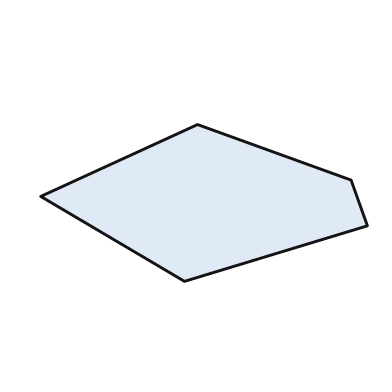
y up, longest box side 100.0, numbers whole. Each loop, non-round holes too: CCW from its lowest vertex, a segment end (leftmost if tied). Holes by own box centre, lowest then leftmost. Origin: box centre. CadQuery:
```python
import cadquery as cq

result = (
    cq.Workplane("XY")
    .moveTo(-6.0, -24.0)
    .lineTo(50.0, -7.0)
    .lineTo(45.0, 7.0)
    .lineTo(-2.0, 24.0)
    .lineTo(-50.0, 2.0)
    .close()
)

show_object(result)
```